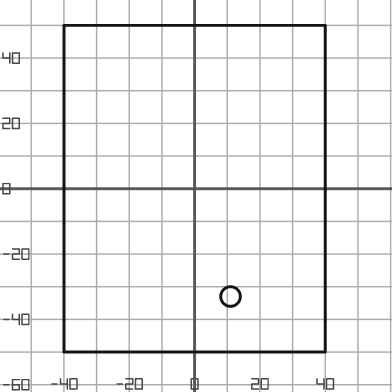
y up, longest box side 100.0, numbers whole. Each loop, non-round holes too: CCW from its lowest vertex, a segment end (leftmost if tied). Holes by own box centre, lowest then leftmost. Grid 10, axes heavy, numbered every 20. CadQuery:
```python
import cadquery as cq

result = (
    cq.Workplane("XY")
    .moveTo(-40.0, -50.0)
    .lineTo(40.0, -50.0)
    .lineTo(40.0, 50.0)
    .lineTo(-40.0, 50.0)
    .close()
    .moveTo(11.0, -33.0)
    .circle(3.0)
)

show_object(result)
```